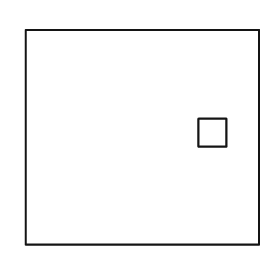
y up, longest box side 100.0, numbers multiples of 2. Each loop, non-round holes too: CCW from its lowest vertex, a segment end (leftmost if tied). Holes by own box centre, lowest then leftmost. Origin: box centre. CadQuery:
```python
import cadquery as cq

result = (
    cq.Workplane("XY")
    .moveTo(-50.0, -46.0)
    .lineTo(50.0, -46.0)
    .lineTo(50.0, 46.0)
    .lineTo(-50.0, 46.0)
    .close()
    .moveTo(24.0, -4.0)
    .lineTo(36.0, -4.0)
    .lineTo(36.0, 8.0)
    .lineTo(24.0, 8.0)
    .close()
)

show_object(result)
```